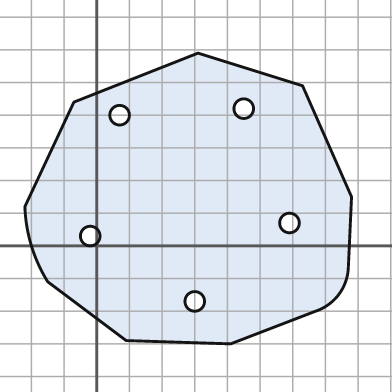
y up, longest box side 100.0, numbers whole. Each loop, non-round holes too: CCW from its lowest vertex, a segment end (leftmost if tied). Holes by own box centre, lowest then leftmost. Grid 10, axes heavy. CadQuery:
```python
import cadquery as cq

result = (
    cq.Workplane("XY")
    .moveTo(41.0, -30.0)
    .lineTo(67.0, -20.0)
    .threePointArc((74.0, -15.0), (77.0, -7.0))
    .lineTo(78.0, 15.0)
    .lineTo(63.0, 49.0)
    .lineTo(31.0, 59.0)
    .lineTo(-7.0, 44.0)
    .lineTo(-22.0, 12.0)
    .threePointArc((-20.0, 0.0), (-15.0, -11.0))
    .lineTo(9.0, -29.0)
    .close()
    .moveTo(30.0, -17.0)
    .circle(3.0)
    .moveTo(-2.0, 3.0)
    .circle(3.0)
    .moveTo(59.0, 7.0)
    .circle(3.0)
    .moveTo(7.0, 40.0)
    .circle(3.0)
    .moveTo(45.0, 42.0)
    .circle(3.0)
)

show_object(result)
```